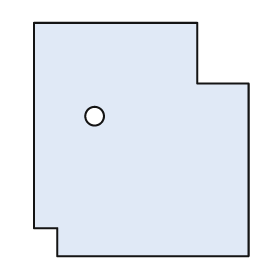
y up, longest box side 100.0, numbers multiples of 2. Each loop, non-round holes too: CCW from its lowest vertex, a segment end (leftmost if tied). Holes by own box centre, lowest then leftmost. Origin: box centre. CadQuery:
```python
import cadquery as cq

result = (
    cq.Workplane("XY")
    .moveTo(-36.0, -50.0)
    .lineTo(46.0, -50.0)
    .lineTo(46.0, 24.0)
    .lineTo(24.0, 24.0)
    .lineTo(24.0, 50.0)
    .lineTo(-46.0, 50.0)
    .lineTo(-46.0, -38.0)
    .lineTo(-36.0, -38.0)
    .close()
    .moveTo(-20.0, 10.0)
    .circle(4.0)
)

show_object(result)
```